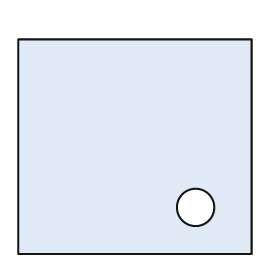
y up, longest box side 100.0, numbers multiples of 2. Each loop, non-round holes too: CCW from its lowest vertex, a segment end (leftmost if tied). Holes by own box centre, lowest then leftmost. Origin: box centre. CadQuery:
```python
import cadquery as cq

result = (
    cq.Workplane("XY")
    .moveTo(-50.0, -46.0)
    .lineTo(50.0, -46.0)
    .lineTo(50.0, 46.0)
    .lineTo(-50.0, 46.0)
    .close()
    .moveTo(26.0, -26.0)
    .circle(8.0)
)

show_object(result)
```